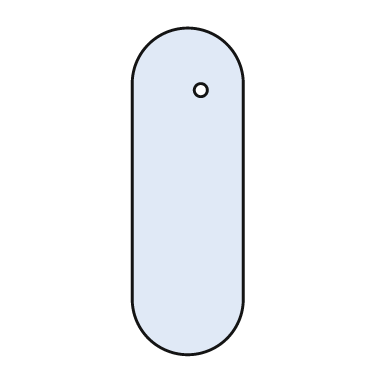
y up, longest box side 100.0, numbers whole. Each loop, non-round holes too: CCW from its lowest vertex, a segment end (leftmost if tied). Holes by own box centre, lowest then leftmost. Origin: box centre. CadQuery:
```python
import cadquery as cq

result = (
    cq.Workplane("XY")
    .moveTo(-17.0, -33.0)
    .threePointArc((0.0, -50.0), (17.0, -33.0))
    .lineTo(17.0, 33.0)
    .threePointArc((0.0, 50.0), (-17.0, 33.0))
    .close()
    .moveTo(4.0, 31.0)
    .circle(2.0)
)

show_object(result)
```